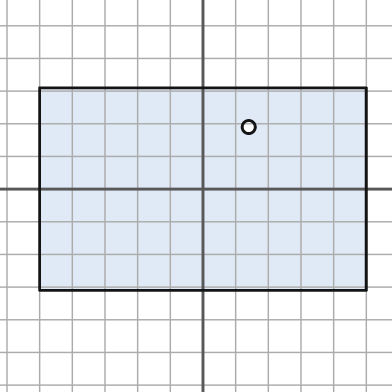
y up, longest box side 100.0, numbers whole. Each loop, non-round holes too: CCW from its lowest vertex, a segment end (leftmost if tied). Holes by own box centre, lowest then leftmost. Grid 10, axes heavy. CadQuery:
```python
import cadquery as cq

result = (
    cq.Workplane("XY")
    .moveTo(-50.0, -31.0)
    .lineTo(50.0, -31.0)
    .lineTo(50.0, 31.0)
    .lineTo(-50.0, 31.0)
    .close()
    .moveTo(14.0, 19.0)
    .circle(2.0)
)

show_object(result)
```